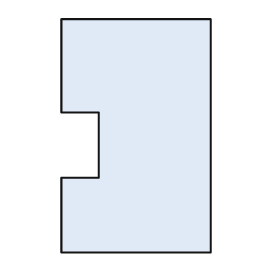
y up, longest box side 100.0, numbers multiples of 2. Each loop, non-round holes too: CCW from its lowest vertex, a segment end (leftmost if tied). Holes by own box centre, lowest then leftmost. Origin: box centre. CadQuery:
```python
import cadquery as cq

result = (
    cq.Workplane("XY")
    .moveTo(-32.0, -50.0)
    .lineTo(32.0, -50.0)
    .lineTo(32.0, 50.0)
    .lineTo(-32.0, 50.0)
    .lineTo(-32.0, 10.0)
    .lineTo(-16.0, 10.0)
    .lineTo(-16.0, -18.0)
    .lineTo(-32.0, -18.0)
    .close()
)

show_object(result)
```